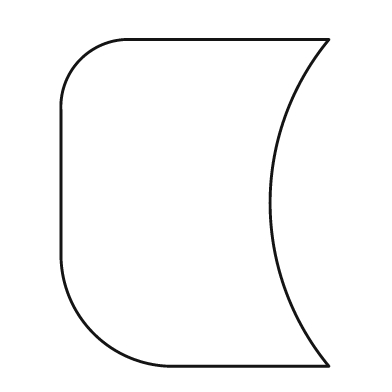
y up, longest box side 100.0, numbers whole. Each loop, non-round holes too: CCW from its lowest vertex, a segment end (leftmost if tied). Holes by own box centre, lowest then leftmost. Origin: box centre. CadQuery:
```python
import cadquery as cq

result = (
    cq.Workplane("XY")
    .moveTo(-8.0, -50.0)
    .lineTo(41.0, -50.0)
    .threePointArc((23.0, 0.0), (41.0, 50.0))
    .lineTo(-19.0, 50.0)
    .threePointArc((-35.0, 44.0), (-41.0, 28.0))
    .lineTo(-41.0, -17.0)
    .threePointArc((-31.0, -40.0), (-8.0, -50.0))
    .close()
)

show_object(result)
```